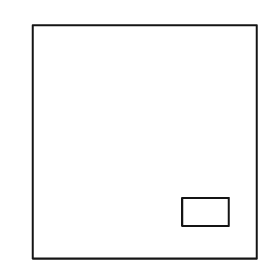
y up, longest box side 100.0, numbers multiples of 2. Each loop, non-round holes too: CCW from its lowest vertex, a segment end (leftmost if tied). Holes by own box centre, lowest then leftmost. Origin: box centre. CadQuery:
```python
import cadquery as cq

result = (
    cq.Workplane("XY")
    .moveTo(-48.0, -50.0)
    .lineTo(48.0, -50.0)
    .lineTo(48.0, 50.0)
    .lineTo(-48.0, 50.0)
    .close()
    .moveTo(16.0, -36.0)
    .lineTo(36.0, -36.0)
    .lineTo(36.0, -24.0)
    .lineTo(16.0, -24.0)
    .close()
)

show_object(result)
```